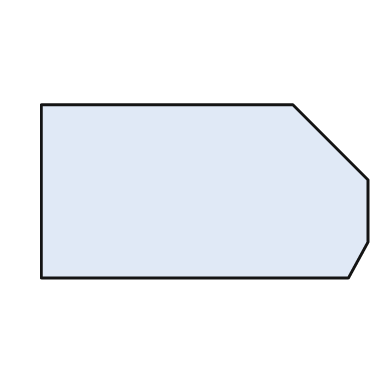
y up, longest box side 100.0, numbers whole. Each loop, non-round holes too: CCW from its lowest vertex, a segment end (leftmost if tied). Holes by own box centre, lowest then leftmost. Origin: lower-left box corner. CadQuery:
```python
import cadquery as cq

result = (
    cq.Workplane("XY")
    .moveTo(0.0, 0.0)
    .lineTo(94.0, 0.0)
    .lineTo(100.0, 11.0)
    .lineTo(100.0, 30.0)
    .lineTo(77.0, 53.0)
    .lineTo(0.0, 53.0)
    .close()
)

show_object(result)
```